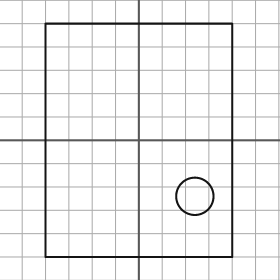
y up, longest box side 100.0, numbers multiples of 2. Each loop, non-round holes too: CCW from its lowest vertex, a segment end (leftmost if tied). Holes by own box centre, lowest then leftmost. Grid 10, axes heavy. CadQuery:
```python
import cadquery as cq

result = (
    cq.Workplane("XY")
    .moveTo(-40.0, -50.0)
    .lineTo(40.0, -50.0)
    .lineTo(40.0, 50.0)
    .lineTo(-40.0, 50.0)
    .close()
    .moveTo(24.0, -24.0)
    .circle(8.0)
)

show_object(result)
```